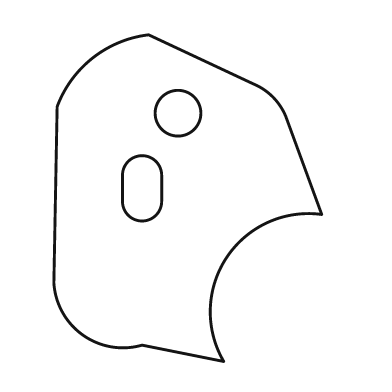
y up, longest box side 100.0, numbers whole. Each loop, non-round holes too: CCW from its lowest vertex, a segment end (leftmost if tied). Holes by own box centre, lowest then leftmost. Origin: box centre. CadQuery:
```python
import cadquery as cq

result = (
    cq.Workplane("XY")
    .moveTo(11.0, -50.0)
    .threePointArc((12.0, -18.0), (41.0, -5.0))
    .lineTo(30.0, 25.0)
    .threePointArc((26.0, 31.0), (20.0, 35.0))
    .lineTo(-12.0, 50.0)
    .threePointArc((-29.0, 43.0), (-40.0, 28.0))
    .lineTo(-41.0, -26.0)
    .threePointArc((-32.0, -42.0), (-14.0, -45.0))
    .close()
    .moveTo(-20.0, -1.0)
    .threePointArc((-14.0, -7.0), (-8.0, -1.0))
    .lineTo(-8.0, 7.0)
    .threePointArc((-14.0, 13.0), (-20.0, 7.0))
    .close()
    .moveTo(-3.0, 26.0)
    .circle(7.0)
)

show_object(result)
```